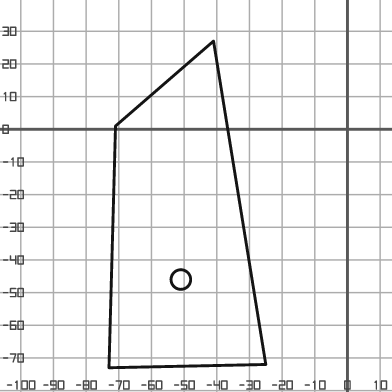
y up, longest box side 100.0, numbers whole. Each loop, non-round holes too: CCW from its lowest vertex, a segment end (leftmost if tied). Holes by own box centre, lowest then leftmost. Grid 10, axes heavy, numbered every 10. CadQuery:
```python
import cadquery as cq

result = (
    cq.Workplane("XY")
    .moveTo(-73.0, -73.0)
    .lineTo(-25.0, -72.0)
    .lineTo(-41.0, 27.0)
    .lineTo(-71.0, 1.0)
    .close()
    .moveTo(-51.0, -46.0)
    .circle(3.0)
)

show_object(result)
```